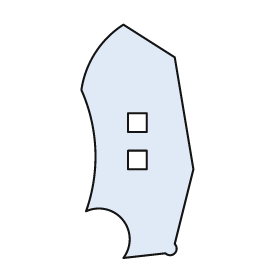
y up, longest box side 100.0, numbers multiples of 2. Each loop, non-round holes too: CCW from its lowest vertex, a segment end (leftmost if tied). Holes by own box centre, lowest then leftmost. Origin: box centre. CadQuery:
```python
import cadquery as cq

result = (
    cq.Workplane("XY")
    .moveTo(-6.0, -50.0)
    .lineTo(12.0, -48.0)
    .threePointArc((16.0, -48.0), (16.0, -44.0))
    .lineTo(24.0, -12.0)
    .lineTo(16.0, 36.0)
    .lineTo(-6.0, 50.0)
    .threePointArc((-18.0, 38.0), (-24.0, 22.0))
    .threePointArc((-18.0, -4.0), (-22.0, -30.0))
    .threePointArc((-6.0, -34.0), (-6.0, -50.0))
    .close()
    .moveTo(-4.0, -12.0)
    .lineTo(4.0, -12.0)
    .lineTo(4.0, -4.0)
    .lineTo(-4.0, -4.0)
    .close()
    .moveTo(-4.0, 4.0)
    .lineTo(4.0, 4.0)
    .lineTo(4.0, 12.0)
    .lineTo(-4.0, 12.0)
    .close()
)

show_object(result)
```